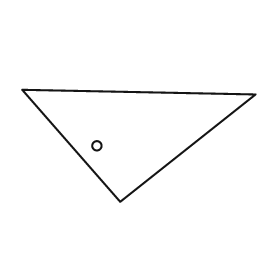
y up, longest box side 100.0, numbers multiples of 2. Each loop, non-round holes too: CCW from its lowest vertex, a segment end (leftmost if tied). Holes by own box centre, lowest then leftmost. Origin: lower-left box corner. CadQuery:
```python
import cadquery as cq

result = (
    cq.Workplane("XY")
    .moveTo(42.0, 0.0)
    .lineTo(100.0, 46.0)
    .lineTo(0.0, 48.0)
    .close()
    .moveTo(32.0, 24.0)
    .circle(2.0)
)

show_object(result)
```